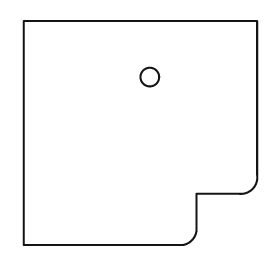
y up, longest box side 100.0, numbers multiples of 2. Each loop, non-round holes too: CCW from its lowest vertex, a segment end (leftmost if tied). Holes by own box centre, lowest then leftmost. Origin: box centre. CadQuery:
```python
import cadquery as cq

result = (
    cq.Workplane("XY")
    .moveTo(-50.0, -48.0)
    .lineTo(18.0, -48.0)
    .threePointArc((22.0, -46.0), (24.0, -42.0))
    .lineTo(24.0, -26.0)
    .lineTo(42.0, -26.0)
    .threePointArc((48.0, -24.0), (50.0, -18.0))
    .lineTo(50.0, 48.0)
    .lineTo(-50.0, 48.0)
    .close()
    .moveTo(4.0, 24.0)
    .circle(4.0)
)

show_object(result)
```